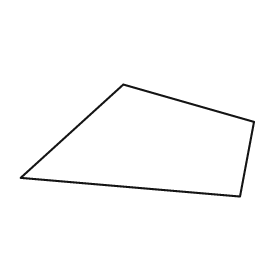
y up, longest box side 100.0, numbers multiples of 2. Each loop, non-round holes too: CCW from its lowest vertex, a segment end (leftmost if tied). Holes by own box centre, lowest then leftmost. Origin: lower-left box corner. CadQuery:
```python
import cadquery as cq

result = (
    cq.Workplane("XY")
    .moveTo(94.0, 0.0)
    .lineTo(100.0, 32.0)
    .lineTo(44.0, 48.0)
    .lineTo(0.0, 8.0)
    .close()
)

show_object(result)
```